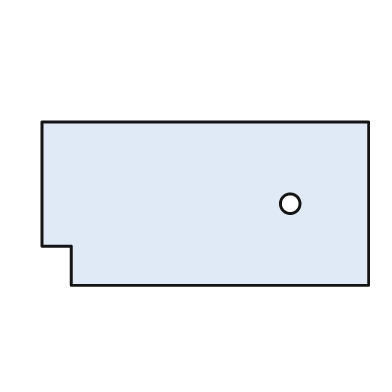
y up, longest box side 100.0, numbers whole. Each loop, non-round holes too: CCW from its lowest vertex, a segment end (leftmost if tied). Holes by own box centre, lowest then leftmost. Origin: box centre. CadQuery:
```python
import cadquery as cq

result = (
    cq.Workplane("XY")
    .moveTo(-41.0, -25.0)
    .lineTo(50.0, -25.0)
    .lineTo(50.0, 25.0)
    .lineTo(-50.0, 25.0)
    .lineTo(-50.0, -13.0)
    .lineTo(-41.0, -13.0)
    .close()
    .moveTo(26.0, 0.0)
    .circle(3.0)
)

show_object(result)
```